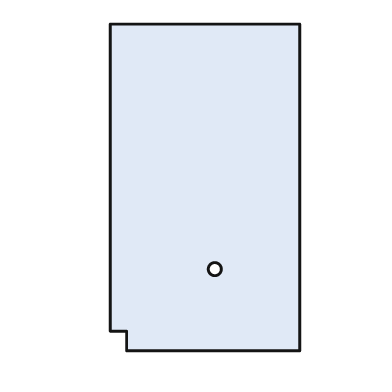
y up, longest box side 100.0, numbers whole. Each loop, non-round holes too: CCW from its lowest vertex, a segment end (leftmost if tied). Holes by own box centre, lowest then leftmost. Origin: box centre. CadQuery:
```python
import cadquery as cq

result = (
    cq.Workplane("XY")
    .moveTo(-24.0, -50.0)
    .lineTo(29.0, -50.0)
    .lineTo(29.0, 50.0)
    .lineTo(-29.0, 50.0)
    .lineTo(-29.0, -44.0)
    .lineTo(-24.0, -44.0)
    .close()
    .moveTo(3.0, -25.0)
    .circle(2.0)
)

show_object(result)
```